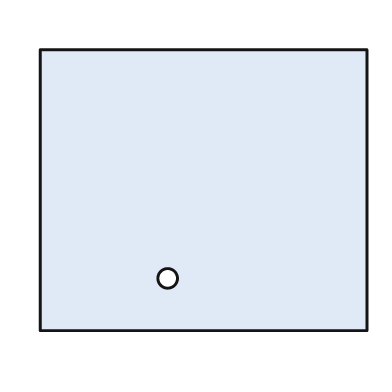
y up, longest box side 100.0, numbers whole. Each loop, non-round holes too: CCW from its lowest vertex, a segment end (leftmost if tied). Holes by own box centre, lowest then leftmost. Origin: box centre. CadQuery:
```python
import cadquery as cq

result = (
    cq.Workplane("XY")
    .moveTo(-50.0, -43.0)
    .lineTo(50.0, -43.0)
    .lineTo(50.0, 43.0)
    .lineTo(-50.0, 43.0)
    .close()
    .moveTo(-11.0, -27.0)
    .circle(3.0)
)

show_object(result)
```